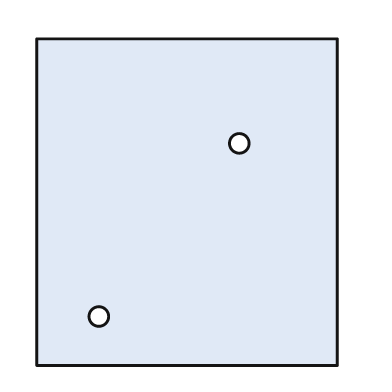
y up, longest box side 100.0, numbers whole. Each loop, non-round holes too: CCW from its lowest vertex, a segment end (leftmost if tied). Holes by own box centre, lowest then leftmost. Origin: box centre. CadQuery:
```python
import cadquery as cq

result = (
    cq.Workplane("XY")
    .moveTo(-46.0, -50.0)
    .lineTo(46.0, -50.0)
    .lineTo(46.0, 50.0)
    .lineTo(-46.0, 50.0)
    .close()
    .moveTo(-27.0, -35.0)
    .circle(3.0)
    .moveTo(16.0, 18.0)
    .circle(3.0)
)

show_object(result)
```